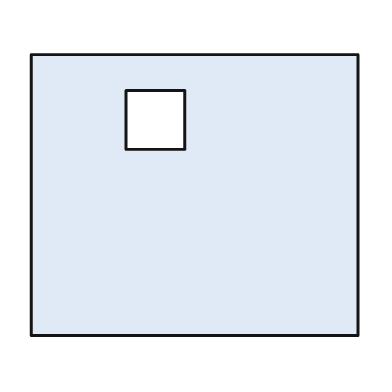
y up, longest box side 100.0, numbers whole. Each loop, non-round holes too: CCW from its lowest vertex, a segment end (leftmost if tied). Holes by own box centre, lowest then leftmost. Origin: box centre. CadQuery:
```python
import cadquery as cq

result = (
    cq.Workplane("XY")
    .moveTo(-50.0, -43.0)
    .lineTo(50.0, -43.0)
    .lineTo(50.0, 43.0)
    .lineTo(-50.0, 43.0)
    .close()
    .moveTo(-21.0, 14.0)
    .lineTo(-3.0, 14.0)
    .lineTo(-3.0, 32.0)
    .lineTo(-21.0, 32.0)
    .close()
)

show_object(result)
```